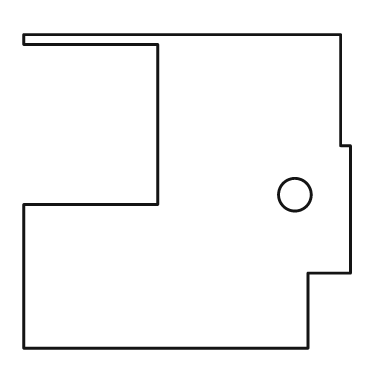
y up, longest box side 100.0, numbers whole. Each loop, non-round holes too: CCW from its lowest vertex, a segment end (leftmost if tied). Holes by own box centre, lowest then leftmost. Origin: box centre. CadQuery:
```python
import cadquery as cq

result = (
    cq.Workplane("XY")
    .moveTo(-50.0, -48.0)
    .lineTo(37.0, -48.0)
    .lineTo(37.0, -25.0)
    .lineTo(50.0, -25.0)
    .lineTo(50.0, 14.0)
    .lineTo(47.0, 14.0)
    .lineTo(47.0, 48.0)
    .lineTo(-50.0, 48.0)
    .lineTo(-50.0, 45.0)
    .lineTo(-9.0, 45.0)
    .lineTo(-9.0, -4.0)
    .lineTo(-50.0, -4.0)
    .close()
    .moveTo(33.0, -1.0)
    .circle(5.0)
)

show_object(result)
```